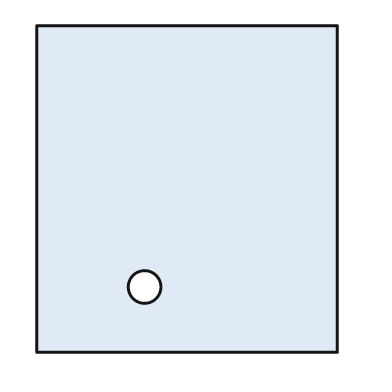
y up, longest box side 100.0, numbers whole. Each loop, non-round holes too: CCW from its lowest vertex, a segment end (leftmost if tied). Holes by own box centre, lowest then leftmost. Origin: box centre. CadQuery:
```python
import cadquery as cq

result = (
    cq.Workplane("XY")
    .moveTo(-46.0, -50.0)
    .lineTo(46.0, -50.0)
    .lineTo(46.0, 50.0)
    .lineTo(-46.0, 50.0)
    .close()
    .moveTo(-13.0, -30.0)
    .circle(5.0)
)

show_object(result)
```